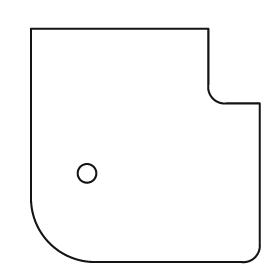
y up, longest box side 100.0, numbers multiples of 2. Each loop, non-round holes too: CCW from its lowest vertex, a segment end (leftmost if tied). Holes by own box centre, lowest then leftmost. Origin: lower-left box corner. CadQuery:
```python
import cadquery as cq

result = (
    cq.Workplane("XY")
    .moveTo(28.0, 0.0)
    .lineTo(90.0, 0.0)
    .threePointArc((96.0, 2.0), (98.0, 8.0))
    .lineTo(98.0, 68.0)
    .lineTo(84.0, 68.0)
    .threePointArc((78.0, 70.0), (76.0, 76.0))
    .lineTo(76.0, 100.0)
    .lineTo(0.0, 100.0)
    .lineTo(0.0, 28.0)
    .threePointArc((8.0, 8.0), (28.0, 0.0))
    .close()
    .moveTo(24.0, 38.0)
    .circle(4.0)
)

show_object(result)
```